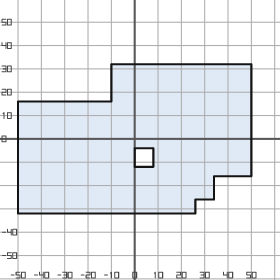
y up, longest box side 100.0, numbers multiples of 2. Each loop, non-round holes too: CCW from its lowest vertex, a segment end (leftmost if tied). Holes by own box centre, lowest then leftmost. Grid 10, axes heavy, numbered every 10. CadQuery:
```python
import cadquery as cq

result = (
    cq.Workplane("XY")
    .moveTo(-50.0, -32.0)
    .lineTo(26.0, -32.0)
    .lineTo(26.0, -26.0)
    .lineTo(34.0, -26.0)
    .lineTo(34.0, -16.0)
    .lineTo(50.0, -16.0)
    .lineTo(50.0, 32.0)
    .lineTo(-10.0, 32.0)
    .lineTo(-10.0, 16.0)
    .lineTo(-50.0, 16.0)
    .close()
    .moveTo(0.0, -12.0)
    .lineTo(8.0, -12.0)
    .lineTo(8.0, -4.0)
    .lineTo(0.0, -4.0)
    .close()
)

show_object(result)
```